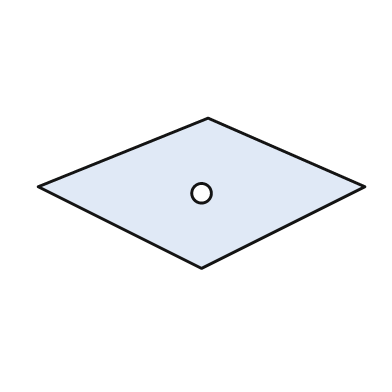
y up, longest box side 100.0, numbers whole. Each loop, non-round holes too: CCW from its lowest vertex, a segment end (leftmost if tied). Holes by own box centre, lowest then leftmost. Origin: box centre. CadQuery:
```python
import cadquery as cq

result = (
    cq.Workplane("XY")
    .moveTo(0.0, -23.0)
    .lineTo(50.0, 2.0)
    .lineTo(2.0, 23.0)
    .lineTo(-50.0, 2.0)
    .close()
    .moveTo(0.0, 0.0)
    .circle(3.0)
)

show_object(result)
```